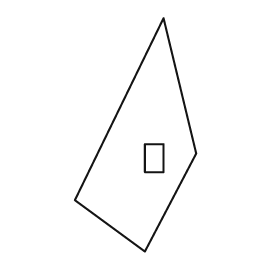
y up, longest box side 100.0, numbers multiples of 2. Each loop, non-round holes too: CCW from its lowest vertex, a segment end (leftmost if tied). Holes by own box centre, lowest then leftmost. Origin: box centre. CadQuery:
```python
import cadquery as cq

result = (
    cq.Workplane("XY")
    .moveTo(4.0, -50.0)
    .lineTo(26.0, -8.0)
    .lineTo(12.0, 50.0)
    .lineTo(-26.0, -28.0)
    .close()
    .moveTo(4.0, -16.0)
    .lineTo(12.0, -16.0)
    .lineTo(12.0, -4.0)
    .lineTo(4.0, -4.0)
    .close()
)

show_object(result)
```